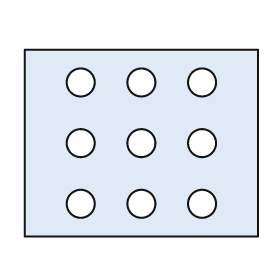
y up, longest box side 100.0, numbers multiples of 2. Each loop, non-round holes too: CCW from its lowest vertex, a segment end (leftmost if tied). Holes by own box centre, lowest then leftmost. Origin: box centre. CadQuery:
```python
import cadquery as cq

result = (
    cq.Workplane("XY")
    .moveTo(-50.0, -40.0)
    .lineTo(50.0, -40.0)
    .lineTo(50.0, 40.0)
    .lineTo(-50.0, 40.0)
    .close()
    .moveTo(-26.0, -26.0)
    .circle(6.0)
    .moveTo(0.0, -26.0)
    .circle(6.0)
    .moveTo(26.0, -26.0)
    .circle(6.0)
    .moveTo(-26.0, 0.0)
    .circle(6.0)
    .moveTo(0.0, 0.0)
    .circle(6.0)
    .moveTo(26.0, 0.0)
    .circle(6.0)
    .moveTo(-26.0, 26.0)
    .circle(6.0)
    .moveTo(0.0, 26.0)
    .circle(6.0)
    .moveTo(26.0, 26.0)
    .circle(6.0)
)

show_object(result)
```